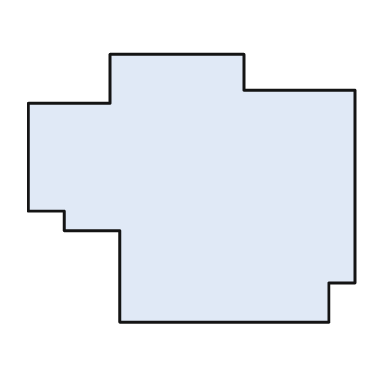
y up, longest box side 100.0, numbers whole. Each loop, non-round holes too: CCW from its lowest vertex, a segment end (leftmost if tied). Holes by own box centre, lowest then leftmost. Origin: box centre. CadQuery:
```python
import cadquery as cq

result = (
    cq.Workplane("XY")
    .moveTo(-22.0, -41.0)
    .lineTo(42.0, -41.0)
    .lineTo(42.0, -29.0)
    .lineTo(50.0, -29.0)
    .lineTo(50.0, 30.0)
    .lineTo(16.0, 30.0)
    .lineTo(16.0, 41.0)
    .lineTo(-25.0, 41.0)
    .lineTo(-25.0, 26.0)
    .lineTo(-50.0, 26.0)
    .lineTo(-50.0, -7.0)
    .lineTo(-39.0, -7.0)
    .lineTo(-39.0, -13.0)
    .lineTo(-22.0, -13.0)
    .close()
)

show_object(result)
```